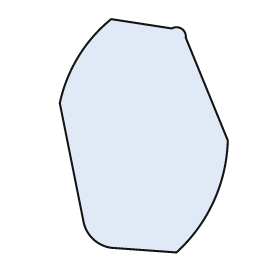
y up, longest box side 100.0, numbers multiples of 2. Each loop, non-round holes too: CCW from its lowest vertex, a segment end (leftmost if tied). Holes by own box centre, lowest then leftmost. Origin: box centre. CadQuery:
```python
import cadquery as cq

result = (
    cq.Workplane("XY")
    .moveTo(14.0, -50.0)
    .threePointArc((30.0, -28.0), (36.0, -2.0))
    .lineTo(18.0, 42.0)
    .threePointArc((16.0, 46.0), (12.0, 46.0))
    .lineTo(-14.0, 50.0)
    .threePointArc((-28.0, 34.0), (-36.0, 14.0))
    .lineTo(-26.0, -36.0)
    .threePointArc((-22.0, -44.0), (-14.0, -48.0))
    .close()
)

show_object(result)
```